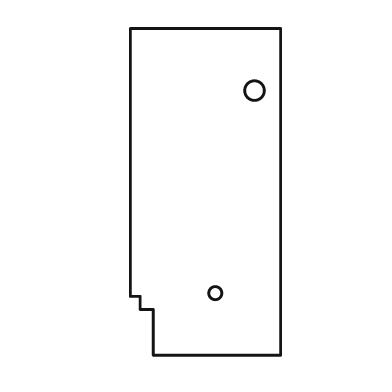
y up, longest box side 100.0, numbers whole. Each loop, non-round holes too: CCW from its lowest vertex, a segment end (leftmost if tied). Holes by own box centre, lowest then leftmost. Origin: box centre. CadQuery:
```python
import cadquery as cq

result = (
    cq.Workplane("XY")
    .moveTo(-16.0, -50.0)
    .lineTo(23.0, -50.0)
    .lineTo(23.0, 50.0)
    .lineTo(-23.0, 50.0)
    .lineTo(-23.0, -32.0)
    .lineTo(-20.0, -32.0)
    .lineTo(-20.0, -36.0)
    .lineTo(-16.0, -36.0)
    .close()
    .moveTo(3.0, -31.0)
    .circle(2.0)
    .moveTo(15.0, 31.0)
    .circle(3.0)
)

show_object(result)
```